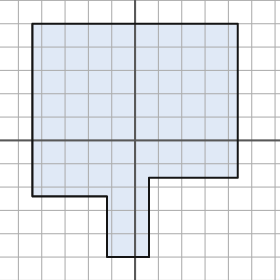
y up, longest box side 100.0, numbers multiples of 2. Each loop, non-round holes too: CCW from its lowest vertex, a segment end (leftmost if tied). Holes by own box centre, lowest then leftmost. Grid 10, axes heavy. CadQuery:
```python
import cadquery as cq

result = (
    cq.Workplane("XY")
    .moveTo(-12.0, -50.0)
    .lineTo(6.0, -50.0)
    .lineTo(6.0, -16.0)
    .lineTo(44.0, -16.0)
    .lineTo(44.0, 50.0)
    .lineTo(-44.0, 50.0)
    .lineTo(-44.0, -24.0)
    .lineTo(-12.0, -24.0)
    .close()
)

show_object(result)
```